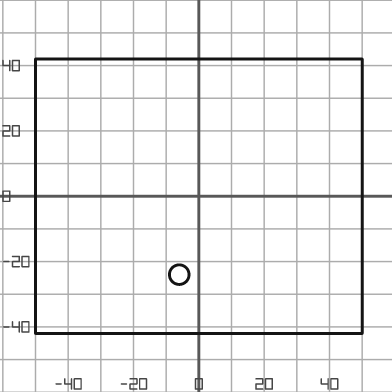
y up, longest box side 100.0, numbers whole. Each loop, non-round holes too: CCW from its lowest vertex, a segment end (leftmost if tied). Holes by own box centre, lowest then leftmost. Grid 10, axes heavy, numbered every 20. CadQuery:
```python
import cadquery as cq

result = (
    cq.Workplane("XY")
    .moveTo(-50.0, -42.0)
    .lineTo(50.0, -42.0)
    .lineTo(50.0, 42.0)
    .lineTo(-50.0, 42.0)
    .close()
    .moveTo(-6.0, -24.0)
    .circle(3.0)
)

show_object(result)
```